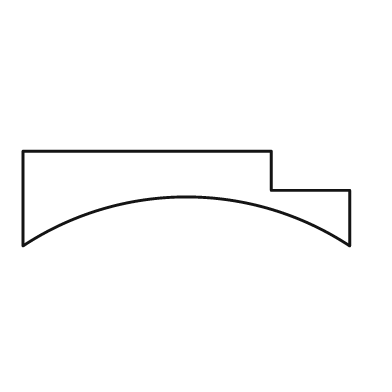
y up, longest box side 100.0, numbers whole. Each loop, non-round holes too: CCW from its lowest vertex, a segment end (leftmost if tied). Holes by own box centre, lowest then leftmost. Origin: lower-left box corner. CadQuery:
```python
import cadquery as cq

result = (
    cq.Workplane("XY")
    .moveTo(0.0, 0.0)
    .threePointArc((50.0, 15.0), (100.0, 0.0))
    .lineTo(100.0, 17.0)
    .lineTo(76.0, 17.0)
    .lineTo(76.0, 29.0)
    .lineTo(0.0, 29.0)
    .close()
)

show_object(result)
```